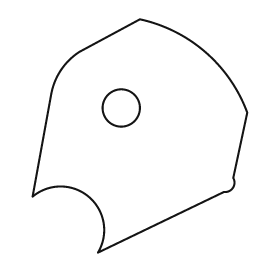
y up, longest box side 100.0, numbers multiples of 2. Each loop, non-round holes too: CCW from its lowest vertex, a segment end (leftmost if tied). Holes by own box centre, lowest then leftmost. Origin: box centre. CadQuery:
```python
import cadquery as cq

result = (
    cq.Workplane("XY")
    .moveTo(-18.0, -50.0)
    .lineTo(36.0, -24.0)
    .threePointArc((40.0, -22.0), (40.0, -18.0))
    .lineTo(46.0, 10.0)
    .threePointArc((28.0, 36.0), (0.0, 50.0))
    .lineTo(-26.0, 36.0)
    .threePointArc((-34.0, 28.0), (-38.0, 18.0))
    .lineTo(-46.0, -26.0)
    .threePointArc((-22.0, -26.0), (-18.0, -50.0))
    .close()
    .moveTo(-8.0, 12.0)
    .circle(8.0)
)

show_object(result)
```